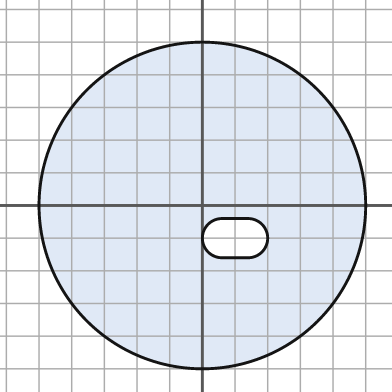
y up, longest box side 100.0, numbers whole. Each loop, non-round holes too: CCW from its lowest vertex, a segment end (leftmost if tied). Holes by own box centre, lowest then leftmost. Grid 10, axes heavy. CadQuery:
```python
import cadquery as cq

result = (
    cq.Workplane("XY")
    .moveTo(0.0, 0.0)
    .circle(50.0)
    .moveTo(6.0, -16.0)
    .lineTo(14.0, -16.0)
    .threePointArc((20.0, -10.0), (14.0, -4.0))
    .lineTo(6.0, -4.0)
    .threePointArc((0.0, -10.0), (6.0, -16.0))
    .close()
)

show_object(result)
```